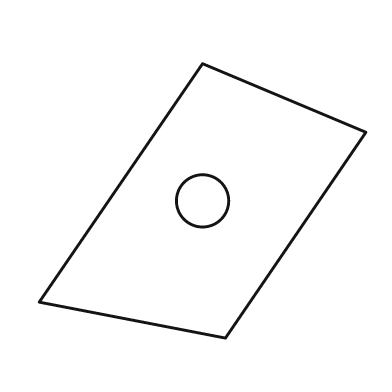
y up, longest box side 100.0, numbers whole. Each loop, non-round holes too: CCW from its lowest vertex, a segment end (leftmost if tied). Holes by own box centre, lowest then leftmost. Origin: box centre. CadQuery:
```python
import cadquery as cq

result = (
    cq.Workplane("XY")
    .moveTo(7.0, -42.0)
    .lineTo(50.0, 21.0)
    .lineTo(0.0, 42.0)
    .lineTo(-50.0, -31.0)
    .close()
    .moveTo(0.0, 0.0)
    .circle(8.0)
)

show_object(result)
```